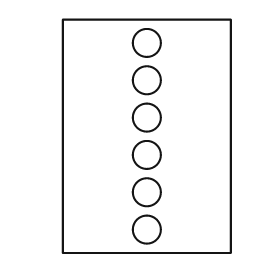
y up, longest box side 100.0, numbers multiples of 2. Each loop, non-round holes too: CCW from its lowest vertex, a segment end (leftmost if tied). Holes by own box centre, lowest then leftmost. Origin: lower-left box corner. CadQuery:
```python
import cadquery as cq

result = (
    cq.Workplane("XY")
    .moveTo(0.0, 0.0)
    .lineTo(72.0, 0.0)
    .lineTo(72.0, 100.0)
    .lineTo(0.0, 100.0)
    .close()
    .moveTo(36.0, 10.0)
    .circle(6.0)
    .moveTo(36.0, 26.0)
    .circle(6.0)
    .moveTo(36.0, 42.0)
    .circle(6.0)
    .moveTo(36.0, 58.0)
    .circle(6.0)
    .moveTo(36.0, 74.0)
    .circle(6.0)
    .moveTo(36.0, 90.0)
    .circle(6.0)
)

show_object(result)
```